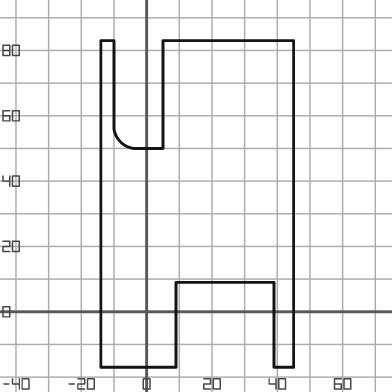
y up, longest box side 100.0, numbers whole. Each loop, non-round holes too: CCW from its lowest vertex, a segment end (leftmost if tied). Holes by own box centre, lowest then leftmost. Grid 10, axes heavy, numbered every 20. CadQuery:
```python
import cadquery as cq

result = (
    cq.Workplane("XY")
    .moveTo(-14.0, -17.0)
    .lineTo(9.0, -17.0)
    .lineTo(9.0, 9.0)
    .lineTo(39.0, 9.0)
    .lineTo(39.0, -17.0)
    .lineTo(45.0, -17.0)
    .lineTo(45.0, 83.0)
    .lineTo(5.0, 83.0)
    .lineTo(5.0, 50.0)
    .lineTo(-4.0, 50.0)
    .threePointArc((-8.0, 52.0), (-10.0, 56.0))
    .lineTo(-10.0, 83.0)
    .lineTo(-14.0, 83.0)
    .close()
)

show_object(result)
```